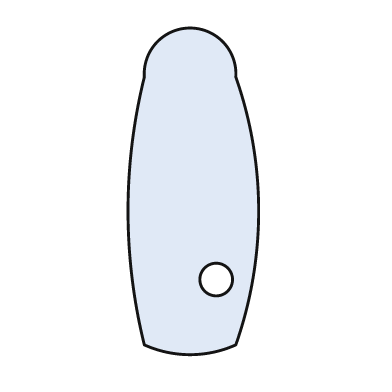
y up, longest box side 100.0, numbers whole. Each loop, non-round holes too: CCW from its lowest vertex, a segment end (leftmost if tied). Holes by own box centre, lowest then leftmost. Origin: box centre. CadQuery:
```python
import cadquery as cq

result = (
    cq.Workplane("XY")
    .moveTo(-15.0, -47.0)
    .threePointArc((-1.0, -50.0), (13.0, -47.0))
    .threePointArc((20.0, -6.0), (13.0, 35.0))
    .threePointArc((-1.0, 50.0), (-15.0, 35.0))
    .threePointArc((-20.0, -6.0), (-15.0, -47.0))
    .close()
    .moveTo(7.0, -27.0)
    .circle(5.0)
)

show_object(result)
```